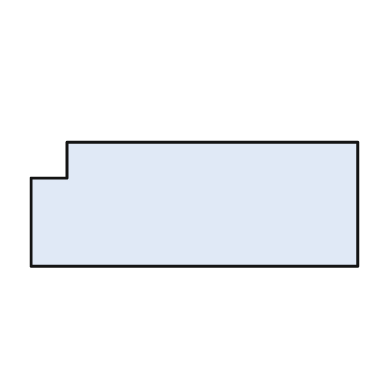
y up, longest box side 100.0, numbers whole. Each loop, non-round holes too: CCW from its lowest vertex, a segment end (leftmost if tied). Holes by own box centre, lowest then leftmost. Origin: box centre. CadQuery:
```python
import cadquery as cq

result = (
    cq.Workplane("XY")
    .moveTo(-50.0, -19.0)
    .lineTo(50.0, -19.0)
    .lineTo(50.0, 19.0)
    .lineTo(-39.0, 19.0)
    .lineTo(-39.0, 8.0)
    .lineTo(-50.0, 8.0)
    .close()
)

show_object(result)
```